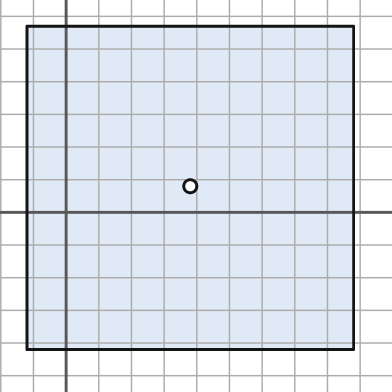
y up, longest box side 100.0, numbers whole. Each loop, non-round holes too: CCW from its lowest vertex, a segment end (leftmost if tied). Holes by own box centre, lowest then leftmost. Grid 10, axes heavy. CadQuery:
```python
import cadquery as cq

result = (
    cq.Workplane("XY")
    .moveTo(-12.0, -42.0)
    .lineTo(88.0, -42.0)
    .lineTo(88.0, 57.0)
    .lineTo(-12.0, 57.0)
    .close()
    .moveTo(38.0, 8.0)
    .circle(2.0)
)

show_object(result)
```